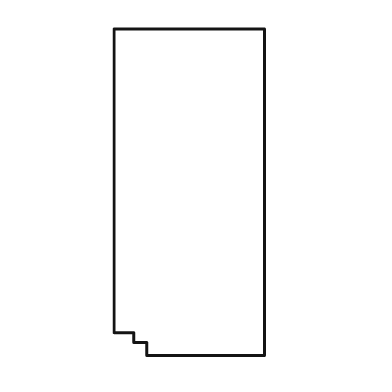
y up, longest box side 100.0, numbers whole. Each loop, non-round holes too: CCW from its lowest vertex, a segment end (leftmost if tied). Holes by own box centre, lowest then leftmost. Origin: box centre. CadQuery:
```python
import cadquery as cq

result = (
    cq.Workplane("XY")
    .moveTo(-13.0, -50.0)
    .lineTo(23.0, -50.0)
    .lineTo(23.0, 50.0)
    .lineTo(-23.0, 50.0)
    .lineTo(-23.0, -43.0)
    .lineTo(-17.0, -43.0)
    .lineTo(-17.0, -46.0)
    .lineTo(-13.0, -46.0)
    .close()
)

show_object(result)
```